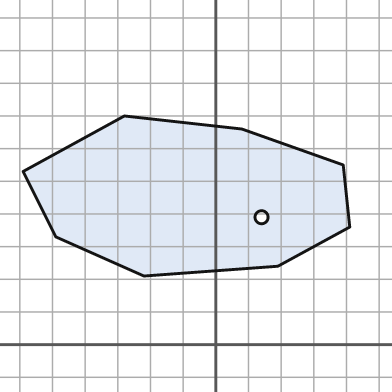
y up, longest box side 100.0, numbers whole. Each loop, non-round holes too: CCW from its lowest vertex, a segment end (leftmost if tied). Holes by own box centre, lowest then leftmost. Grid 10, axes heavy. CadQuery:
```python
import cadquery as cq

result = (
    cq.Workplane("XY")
    .moveTo(-22.0, 21.0)
    .lineTo(19.0, 24.0)
    .lineTo(41.0, 36.0)
    .lineTo(39.0, 55.0)
    .lineTo(8.0, 66.0)
    .lineTo(-28.0, 70.0)
    .lineTo(-59.0, 53.0)
    .lineTo(-49.0, 33.0)
    .close()
    .moveTo(14.0, 39.0)
    .circle(2.0)
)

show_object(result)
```